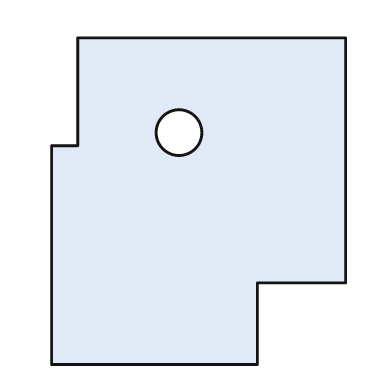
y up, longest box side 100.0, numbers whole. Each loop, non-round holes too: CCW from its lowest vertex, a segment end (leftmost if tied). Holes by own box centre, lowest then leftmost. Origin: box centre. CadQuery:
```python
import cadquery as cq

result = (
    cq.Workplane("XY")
    .moveTo(-45.0, -50.0)
    .lineTo(18.0, -50.0)
    .lineTo(18.0, -25.0)
    .lineTo(45.0, -25.0)
    .lineTo(45.0, 50.0)
    .lineTo(-37.0, 50.0)
    .lineTo(-37.0, 17.0)
    .lineTo(-45.0, 17.0)
    .close()
    .moveTo(-6.0, 21.0)
    .circle(7.0)
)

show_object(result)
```